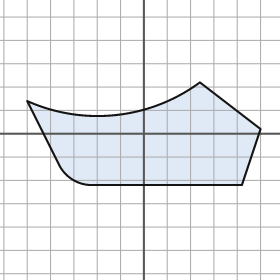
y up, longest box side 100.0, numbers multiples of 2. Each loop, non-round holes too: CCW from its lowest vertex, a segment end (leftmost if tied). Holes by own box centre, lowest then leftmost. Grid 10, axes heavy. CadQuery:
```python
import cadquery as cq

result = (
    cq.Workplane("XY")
    .moveTo(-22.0, -22.0)
    .lineTo(42.0, -22.0)
    .lineTo(50.0, 2.0)
    .lineTo(24.0, 22.0)
    .threePointArc((-12.0, 8.0), (-50.0, 14.0))
    .lineTo(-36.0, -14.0)
    .threePointArc((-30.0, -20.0), (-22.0, -22.0))
    .close()
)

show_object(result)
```